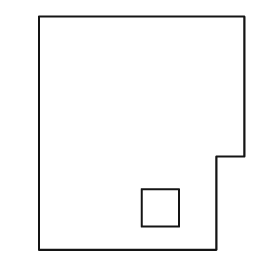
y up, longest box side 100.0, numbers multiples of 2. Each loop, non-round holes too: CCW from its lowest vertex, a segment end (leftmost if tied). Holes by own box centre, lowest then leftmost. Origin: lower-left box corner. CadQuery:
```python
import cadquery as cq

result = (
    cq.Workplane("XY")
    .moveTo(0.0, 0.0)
    .lineTo(76.0, 0.0)
    .lineTo(76.0, 40.0)
    .lineTo(88.0, 40.0)
    .lineTo(88.0, 100.0)
    .lineTo(0.0, 100.0)
    .close()
    .moveTo(44.0, 10.0)
    .lineTo(60.0, 10.0)
    .lineTo(60.0, 26.0)
    .lineTo(44.0, 26.0)
    .close()
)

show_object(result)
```